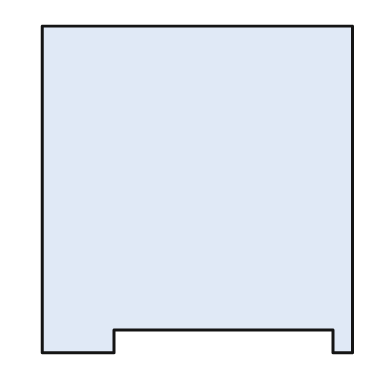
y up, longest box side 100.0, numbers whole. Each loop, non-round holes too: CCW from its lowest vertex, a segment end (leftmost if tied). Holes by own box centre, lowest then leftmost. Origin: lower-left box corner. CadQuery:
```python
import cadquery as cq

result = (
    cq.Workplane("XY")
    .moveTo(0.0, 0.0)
    .lineTo(22.0, 0.0)
    .lineTo(22.0, 7.0)
    .lineTo(89.0, 7.0)
    .lineTo(89.0, 0.0)
    .lineTo(95.0, 0.0)
    .lineTo(95.0, 100.0)
    .lineTo(0.0, 100.0)
    .close()
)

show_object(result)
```